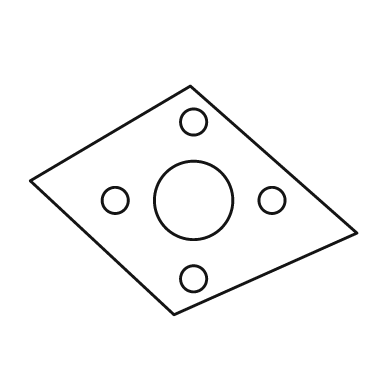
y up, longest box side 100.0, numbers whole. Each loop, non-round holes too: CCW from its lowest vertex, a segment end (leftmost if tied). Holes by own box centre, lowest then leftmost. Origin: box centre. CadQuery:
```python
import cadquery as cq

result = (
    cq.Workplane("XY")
    .moveTo(-6.0, -35.0)
    .lineTo(50.0, -10.0)
    .lineTo(-1.0, 35.0)
    .lineTo(-50.0, 6.0)
    .close()
    .moveTo(0.0, -24.0)
    .circle(4.0)
    .moveTo(-24.0, 0.0)
    .circle(4.0)
    .moveTo(0.0, 0.0)
    .circle(12.0)
    .moveTo(24.0, 0.0)
    .circle(4.0)
    .moveTo(0.0, 24.0)
    .circle(4.0)
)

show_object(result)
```